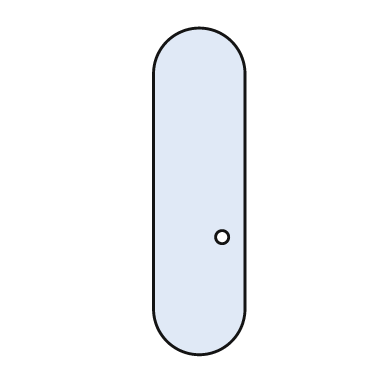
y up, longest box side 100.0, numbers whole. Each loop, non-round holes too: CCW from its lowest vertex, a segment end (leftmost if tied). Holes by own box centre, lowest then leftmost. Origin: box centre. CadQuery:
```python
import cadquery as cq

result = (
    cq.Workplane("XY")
    .moveTo(-14.0, -36.0)
    .threePointArc((0.0, -50.0), (14.0, -36.0))
    .lineTo(14.0, 36.0)
    .threePointArc((0.0, 50.0), (-14.0, 36.0))
    .close()
    .moveTo(7.0, -14.0)
    .circle(2.0)
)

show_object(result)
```